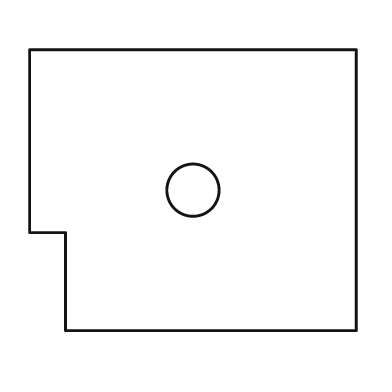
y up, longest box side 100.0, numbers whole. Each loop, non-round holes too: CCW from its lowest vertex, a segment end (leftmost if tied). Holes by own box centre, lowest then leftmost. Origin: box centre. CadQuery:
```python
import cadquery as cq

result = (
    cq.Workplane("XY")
    .moveTo(-39.0, -43.0)
    .lineTo(50.0, -43.0)
    .lineTo(50.0, 43.0)
    .lineTo(-50.0, 43.0)
    .lineTo(-50.0, -13.0)
    .lineTo(-39.0, -13.0)
    .close()
    .moveTo(0.0, 0.0)
    .circle(8.0)
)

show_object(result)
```